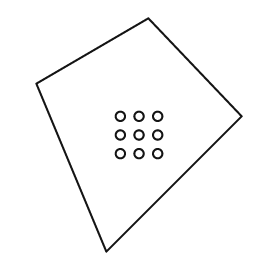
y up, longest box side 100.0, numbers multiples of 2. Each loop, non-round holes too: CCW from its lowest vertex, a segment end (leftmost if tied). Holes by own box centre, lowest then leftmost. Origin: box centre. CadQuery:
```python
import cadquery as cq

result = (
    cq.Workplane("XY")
    .moveTo(-14.0, -50.0)
    .lineTo(44.0, 8.0)
    .lineTo(4.0, 50.0)
    .lineTo(-44.0, 22.0)
    .close()
    .moveTo(-8.0, -8.0)
    .circle(2.0)
    .moveTo(0.0, -8.0)
    .circle(2.0)
    .moveTo(8.0, -8.0)
    .circle(2.0)
    .moveTo(-8.0, 0.0)
    .circle(2.0)
    .moveTo(0.0, 0.0)
    .circle(2.0)
    .moveTo(8.0, 0.0)
    .circle(2.0)
    .moveTo(-8.0, 8.0)
    .circle(2.0)
    .moveTo(0.0, 8.0)
    .circle(2.0)
    .moveTo(8.0, 8.0)
    .circle(2.0)
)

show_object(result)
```